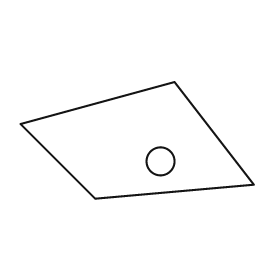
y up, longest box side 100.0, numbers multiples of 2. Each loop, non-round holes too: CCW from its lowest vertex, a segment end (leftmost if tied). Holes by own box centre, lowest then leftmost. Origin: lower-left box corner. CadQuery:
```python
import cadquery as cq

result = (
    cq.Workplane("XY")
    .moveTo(32.0, 0.0)
    .lineTo(100.0, 6.0)
    .lineTo(66.0, 50.0)
    .lineTo(0.0, 32.0)
    .close()
    .moveTo(60.0, 16.0)
    .circle(6.0)
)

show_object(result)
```